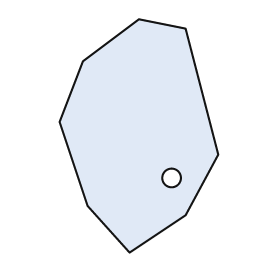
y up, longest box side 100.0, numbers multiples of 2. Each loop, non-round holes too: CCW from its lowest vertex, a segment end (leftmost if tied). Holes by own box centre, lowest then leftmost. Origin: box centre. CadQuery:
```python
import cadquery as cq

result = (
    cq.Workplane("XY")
    .moveTo(-4.0, -50.0)
    .lineTo(20.0, -34.0)
    .lineTo(34.0, -8.0)
    .lineTo(20.0, 46.0)
    .lineTo(0.0, 50.0)
    .lineTo(-24.0, 32.0)
    .lineTo(-34.0, 6.0)
    .lineTo(-22.0, -30.0)
    .close()
    .moveTo(14.0, -18.0)
    .circle(4.0)
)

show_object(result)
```